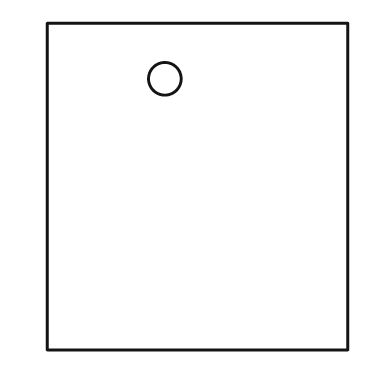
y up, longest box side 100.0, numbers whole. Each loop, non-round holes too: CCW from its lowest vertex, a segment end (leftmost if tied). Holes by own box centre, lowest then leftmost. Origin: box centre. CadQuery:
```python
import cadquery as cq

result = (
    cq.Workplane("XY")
    .moveTo(-46.0, -50.0)
    .lineTo(46.0, -50.0)
    .lineTo(46.0, 50.0)
    .lineTo(-46.0, 50.0)
    .close()
    .moveTo(-10.0, 33.0)
    .circle(5.0)
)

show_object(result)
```